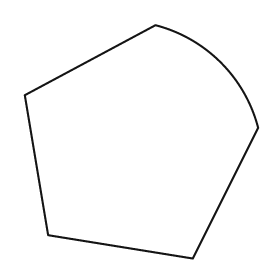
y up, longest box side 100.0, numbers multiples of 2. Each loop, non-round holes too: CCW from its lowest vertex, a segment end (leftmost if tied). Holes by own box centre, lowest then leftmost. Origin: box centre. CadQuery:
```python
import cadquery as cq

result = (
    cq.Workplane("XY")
    .moveTo(22.0, -50.0)
    .lineTo(50.0, 6.0)
    .threePointArc((34.0, 34.0), (6.0, 50.0))
    .lineTo(-50.0, 20.0)
    .lineTo(-40.0, -40.0)
    .close()
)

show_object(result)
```